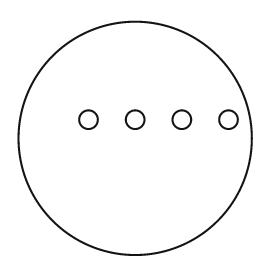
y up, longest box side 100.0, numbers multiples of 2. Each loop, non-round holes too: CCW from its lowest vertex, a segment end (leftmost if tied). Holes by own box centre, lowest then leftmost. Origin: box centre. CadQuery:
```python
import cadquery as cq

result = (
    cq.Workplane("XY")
    .moveTo(0.0, 0.0)
    .circle(50.0)
    .moveTo(-20.0, 8.0)
    .circle(4.0)
    .moveTo(0.0, 8.0)
    .circle(4.0)
    .moveTo(20.0, 8.0)
    .circle(4.0)
    .moveTo(40.0, 8.0)
    .circle(4.0)
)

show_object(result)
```